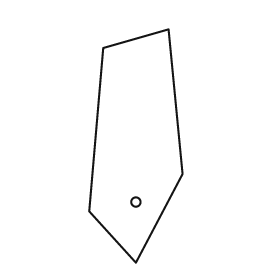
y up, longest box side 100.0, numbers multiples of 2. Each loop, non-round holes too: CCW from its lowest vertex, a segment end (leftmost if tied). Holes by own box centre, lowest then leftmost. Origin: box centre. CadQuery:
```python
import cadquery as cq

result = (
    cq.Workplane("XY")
    .moveTo(0.0, -50.0)
    .lineTo(20.0, -12.0)
    .lineTo(14.0, 50.0)
    .lineTo(-14.0, 42.0)
    .lineTo(-20.0, -28.0)
    .close()
    .moveTo(0.0, -24.0)
    .circle(2.0)
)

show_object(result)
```